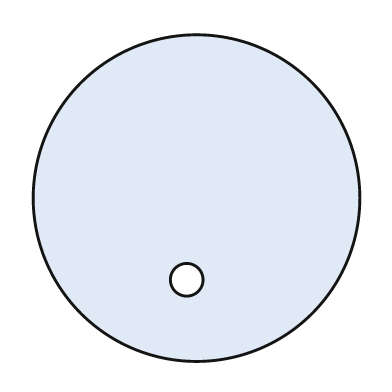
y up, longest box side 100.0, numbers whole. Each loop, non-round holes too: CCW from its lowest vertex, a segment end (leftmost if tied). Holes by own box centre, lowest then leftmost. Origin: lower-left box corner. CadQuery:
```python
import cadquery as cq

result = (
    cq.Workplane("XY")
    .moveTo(50.0, 50.0)
    .circle(50.0)
    .moveTo(47.0, 25.0)
    .circle(5.0)
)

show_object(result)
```